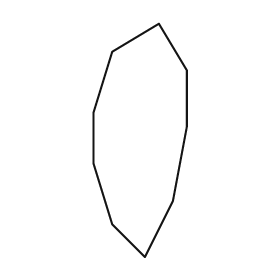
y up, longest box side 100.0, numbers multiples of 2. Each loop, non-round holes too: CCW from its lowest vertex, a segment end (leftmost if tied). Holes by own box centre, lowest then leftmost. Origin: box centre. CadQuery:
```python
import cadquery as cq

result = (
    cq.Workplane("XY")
    .moveTo(2.0, -50.0)
    .lineTo(14.0, -26.0)
    .lineTo(20.0, 6.0)
    .lineTo(20.0, 30.0)
    .lineTo(8.0, 50.0)
    .lineTo(-12.0, 38.0)
    .lineTo(-20.0, 12.0)
    .lineTo(-20.0, -10.0)
    .lineTo(-12.0, -36.0)
    .close()
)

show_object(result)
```